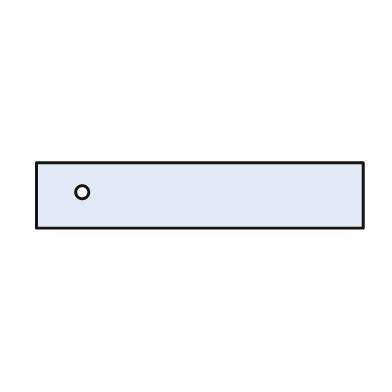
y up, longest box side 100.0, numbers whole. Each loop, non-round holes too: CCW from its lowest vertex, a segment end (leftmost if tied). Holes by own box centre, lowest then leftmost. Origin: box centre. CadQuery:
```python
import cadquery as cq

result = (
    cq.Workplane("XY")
    .moveTo(-50.0, -10.0)
    .lineTo(50.0, -10.0)
    .lineTo(50.0, 10.0)
    .lineTo(-50.0, 10.0)
    .close()
    .moveTo(-36.0, 1.0)
    .circle(2.0)
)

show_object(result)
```